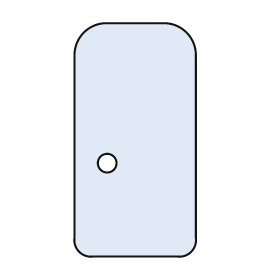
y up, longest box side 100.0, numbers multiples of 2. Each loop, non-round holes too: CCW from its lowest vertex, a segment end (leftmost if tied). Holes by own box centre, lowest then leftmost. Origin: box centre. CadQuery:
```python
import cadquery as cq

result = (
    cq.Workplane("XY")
    .moveTo(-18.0, -50.0)
    .lineTo(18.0, -50.0)
    .threePointArc((24.0, -48.0), (26.0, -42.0))
    .lineTo(26.0, 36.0)
    .threePointArc((22.0, 46.0), (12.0, 50.0))
    .lineTo(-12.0, 50.0)
    .threePointArc((-22.0, 46.0), (-26.0, 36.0))
    .lineTo(-26.0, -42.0)
    .threePointArc((-24.0, -48.0), (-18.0, -50.0))
    .close()
    .moveTo(-12.0, -10.0)
    .circle(4.0)
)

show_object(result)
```